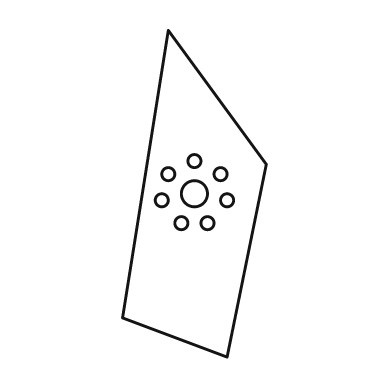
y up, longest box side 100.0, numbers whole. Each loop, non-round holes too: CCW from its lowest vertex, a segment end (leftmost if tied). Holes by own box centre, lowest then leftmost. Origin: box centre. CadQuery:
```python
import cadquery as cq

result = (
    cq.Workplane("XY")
    .moveTo(10.0, -50.0)
    .lineTo(22.0, 9.0)
    .lineTo(-8.0, 50.0)
    .lineTo(-22.0, -38.0)
    .close()
    .moveTo(-4.0, -9.0)
    .circle(2.0)
    .moveTo(4.0, -9.0)
    .circle(2.0)
    .moveTo(-10.0, -2.0)
    .circle(2.0)
    .moveTo(10.0, -2.0)
    .circle(2.0)
    .moveTo(0.0, 0.0)
    .circle(4.0)
    .moveTo(-8.0, 6.0)
    .circle(2.0)
    .moveTo(8.0, 6.0)
    .circle(2.0)
    .moveTo(0.0, 10.0)
    .circle(2.0)
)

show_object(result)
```